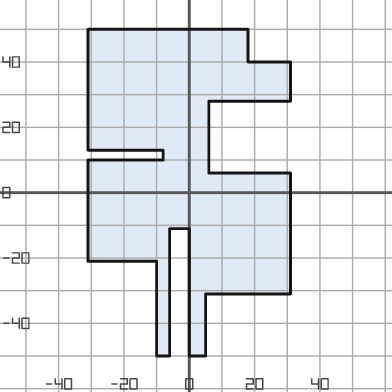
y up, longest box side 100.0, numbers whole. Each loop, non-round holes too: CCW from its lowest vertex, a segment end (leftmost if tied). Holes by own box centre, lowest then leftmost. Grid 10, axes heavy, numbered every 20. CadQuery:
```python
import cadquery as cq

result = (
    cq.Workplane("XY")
    .moveTo(-10.0, -50.0)
    .lineTo(-6.0, -50.0)
    .lineTo(-6.0, -11.0)
    .lineTo(0.0, -11.0)
    .lineTo(0.0, -50.0)
    .lineTo(5.0, -50.0)
    .lineTo(5.0, -31.0)
    .lineTo(31.0, -31.0)
    .lineTo(31.0, 6.0)
    .lineTo(6.0, 6.0)
    .lineTo(6.0, 28.0)
    .lineTo(31.0, 28.0)
    .lineTo(31.0, 40.0)
    .lineTo(18.0, 40.0)
    .lineTo(18.0, 50.0)
    .lineTo(-31.0, 50.0)
    .lineTo(-31.0, 13.0)
    .lineTo(-8.0, 13.0)
    .lineTo(-8.0, 10.0)
    .lineTo(-31.0, 10.0)
    .lineTo(-31.0, -21.0)
    .lineTo(-10.0, -21.0)
    .close()
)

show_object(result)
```